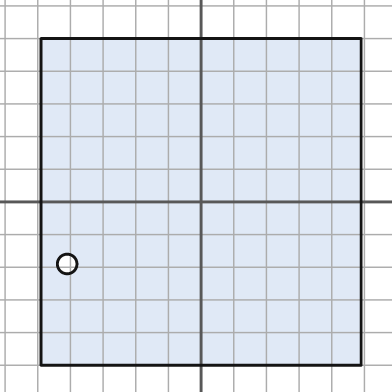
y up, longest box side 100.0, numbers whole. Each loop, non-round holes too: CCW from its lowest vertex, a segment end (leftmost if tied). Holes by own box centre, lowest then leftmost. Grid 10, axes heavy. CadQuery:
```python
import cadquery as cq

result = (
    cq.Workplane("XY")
    .moveTo(-49.0, -50.0)
    .lineTo(49.0, -50.0)
    .lineTo(49.0, 50.0)
    .lineTo(-49.0, 50.0)
    .close()
    .moveTo(-41.0, -19.0)
    .circle(3.0)
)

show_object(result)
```